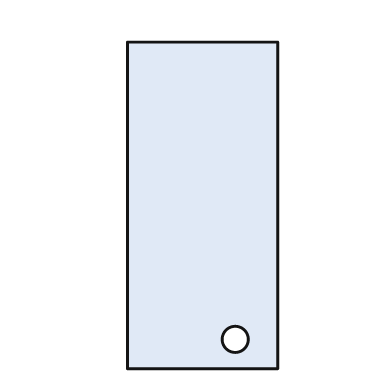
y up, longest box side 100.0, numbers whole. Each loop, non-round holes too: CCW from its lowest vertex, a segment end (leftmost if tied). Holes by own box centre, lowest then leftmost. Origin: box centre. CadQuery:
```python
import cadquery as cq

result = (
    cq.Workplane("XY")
    .moveTo(-23.0, -50.0)
    .lineTo(23.0, -50.0)
    .lineTo(23.0, 50.0)
    .lineTo(-23.0, 50.0)
    .close()
    .moveTo(10.0, -41.0)
    .circle(4.0)
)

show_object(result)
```